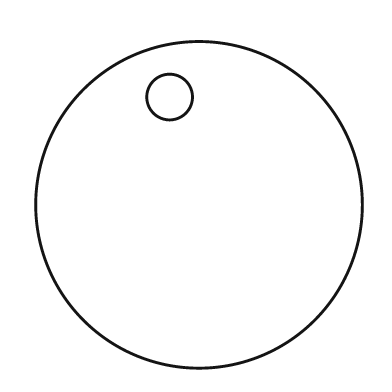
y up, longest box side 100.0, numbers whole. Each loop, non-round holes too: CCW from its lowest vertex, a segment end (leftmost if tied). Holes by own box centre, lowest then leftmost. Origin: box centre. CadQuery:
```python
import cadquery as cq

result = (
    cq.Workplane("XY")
    .moveTo(0.0, 0.0)
    .circle(50.0)
    .moveTo(-9.0, 33.0)
    .circle(7.0)
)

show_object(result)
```